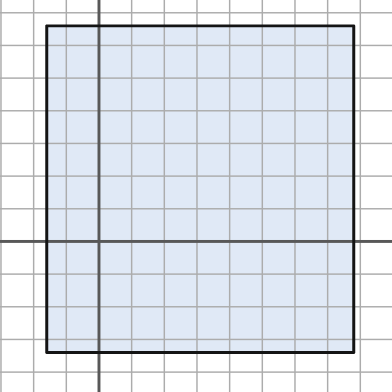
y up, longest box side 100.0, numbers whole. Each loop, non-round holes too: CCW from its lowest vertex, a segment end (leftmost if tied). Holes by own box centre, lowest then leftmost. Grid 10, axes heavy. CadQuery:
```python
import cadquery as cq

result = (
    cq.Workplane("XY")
    .moveTo(-16.0, -34.0)
    .lineTo(78.0, -34.0)
    .lineTo(78.0, 66.0)
    .lineTo(-16.0, 66.0)
    .close()
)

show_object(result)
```